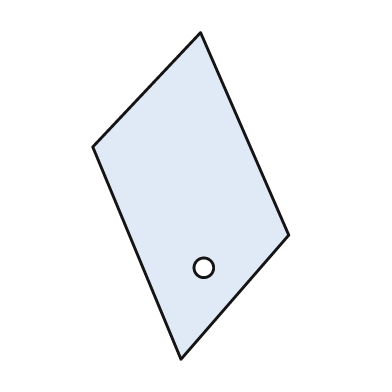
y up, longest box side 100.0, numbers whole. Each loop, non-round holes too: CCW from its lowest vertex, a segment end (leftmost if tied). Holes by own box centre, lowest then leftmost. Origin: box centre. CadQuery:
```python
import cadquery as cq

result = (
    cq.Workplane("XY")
    .moveTo(-3.0, -50.0)
    .lineTo(30.0, -12.0)
    .lineTo(3.0, 50.0)
    .lineTo(-30.0, 15.0)
    .close()
    .moveTo(4.0, -22.0)
    .circle(3.0)
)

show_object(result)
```